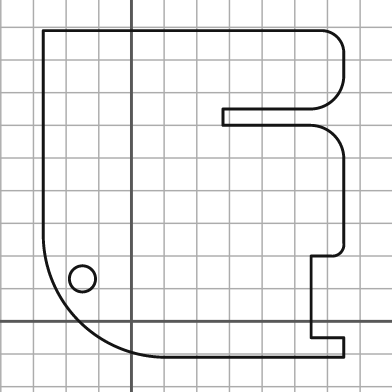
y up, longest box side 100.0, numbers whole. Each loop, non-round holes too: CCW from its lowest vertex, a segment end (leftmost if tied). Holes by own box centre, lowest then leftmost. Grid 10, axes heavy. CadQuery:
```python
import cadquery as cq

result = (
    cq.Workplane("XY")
    .moveTo(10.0, -11.0)
    .lineTo(65.0, -11.0)
    .lineTo(65.0, -5.0)
    .lineTo(55.0, -5.0)
    .lineTo(55.0, 20.0)
    .lineTo(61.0, 20.0)
    .threePointArc((64.0, 21.0), (65.0, 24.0))
    .lineTo(65.0, 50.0)
    .threePointArc((62.0, 57.0), (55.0, 60.0))
    .lineTo(28.0, 60.0)
    .lineTo(28.0, 65.0)
    .lineTo(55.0, 65.0)
    .threePointArc((62.0, 68.0), (65.0, 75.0))
    .lineTo(65.0, 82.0)
    .threePointArc((63.0, 87.0), (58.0, 89.0))
    .lineTo(-27.0, 89.0)
    .lineTo(-27.0, 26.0)
    .threePointArc((-16.0, 0.0), (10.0, -11.0))
    .close()
    .moveTo(-15.0, 13.0)
    .circle(4.0)
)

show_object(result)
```